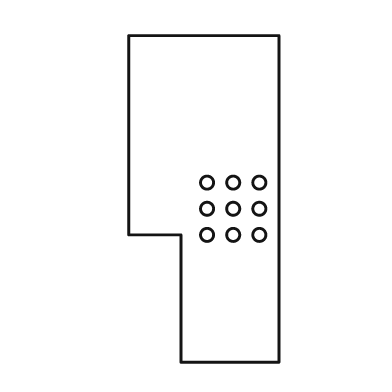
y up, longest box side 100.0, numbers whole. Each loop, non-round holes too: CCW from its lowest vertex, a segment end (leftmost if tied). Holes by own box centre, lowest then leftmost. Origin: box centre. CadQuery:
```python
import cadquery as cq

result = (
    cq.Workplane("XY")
    .moveTo(-7.0, -50.0)
    .lineTo(23.0, -50.0)
    .lineTo(23.0, 50.0)
    .lineTo(-23.0, 50.0)
    .lineTo(-23.0, -11.0)
    .lineTo(-7.0, -11.0)
    .close()
    .moveTo(1.0, -11.0)
    .circle(2.0)
    .moveTo(9.0, -11.0)
    .circle(2.0)
    .moveTo(17.0, -11.0)
    .circle(2.0)
    .moveTo(1.0, -3.0)
    .circle(2.0)
    .moveTo(9.0, -3.0)
    .circle(2.0)
    .moveTo(17.0, -3.0)
    .circle(2.0)
    .moveTo(1.0, 5.0)
    .circle(2.0)
    .moveTo(9.0, 5.0)
    .circle(2.0)
    .moveTo(17.0, 5.0)
    .circle(2.0)
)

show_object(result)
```